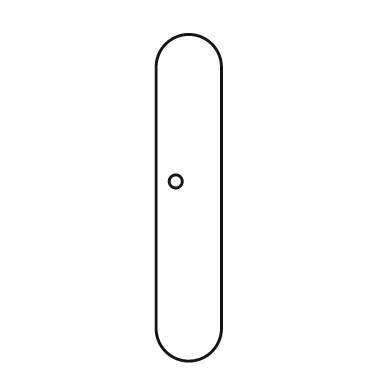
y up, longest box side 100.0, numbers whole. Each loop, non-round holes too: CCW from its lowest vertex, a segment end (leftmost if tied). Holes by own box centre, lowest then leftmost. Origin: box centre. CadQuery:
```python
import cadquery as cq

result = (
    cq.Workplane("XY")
    .moveTo(-10.0, -40.0)
    .threePointArc((0.0, -50.0), (10.0, -40.0))
    .lineTo(10.0, 40.0)
    .threePointArc((0.0, 50.0), (-10.0, 40.0))
    .close()
    .moveTo(-4.0, 5.0)
    .circle(2.0)
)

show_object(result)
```